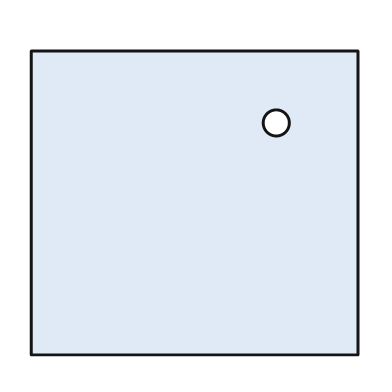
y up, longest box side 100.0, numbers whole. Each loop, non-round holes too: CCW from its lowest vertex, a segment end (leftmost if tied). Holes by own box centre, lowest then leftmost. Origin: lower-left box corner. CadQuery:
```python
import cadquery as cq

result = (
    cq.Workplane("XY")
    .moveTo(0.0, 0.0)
    .lineTo(100.0, 0.0)
    .lineTo(100.0, 93.0)
    .lineTo(0.0, 93.0)
    .close()
    .moveTo(75.0, 71.0)
    .circle(4.0)
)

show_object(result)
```